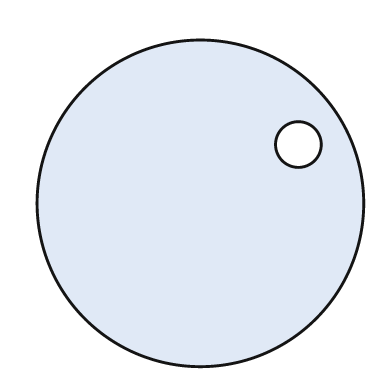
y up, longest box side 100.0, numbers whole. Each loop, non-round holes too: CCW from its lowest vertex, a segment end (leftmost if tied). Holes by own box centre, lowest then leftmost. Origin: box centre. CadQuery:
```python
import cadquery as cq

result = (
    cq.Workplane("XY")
    .moveTo(0.0, 0.0)
    .circle(50.0)
    .moveTo(30.0, 18.0)
    .circle(7.0)
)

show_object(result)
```